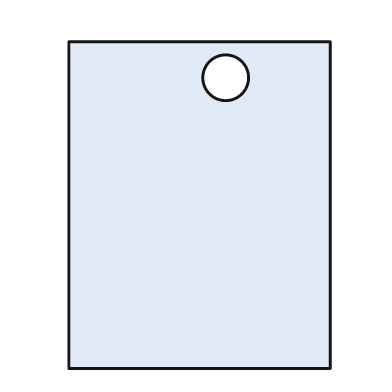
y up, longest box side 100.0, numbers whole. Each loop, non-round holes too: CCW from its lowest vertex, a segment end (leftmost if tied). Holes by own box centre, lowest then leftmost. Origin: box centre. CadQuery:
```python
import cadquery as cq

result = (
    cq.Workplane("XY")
    .moveTo(-40.0, -50.0)
    .lineTo(40.0, -50.0)
    .lineTo(40.0, 50.0)
    .lineTo(-40.0, 50.0)
    .close()
    .moveTo(8.0, 39.0)
    .circle(7.0)
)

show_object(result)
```